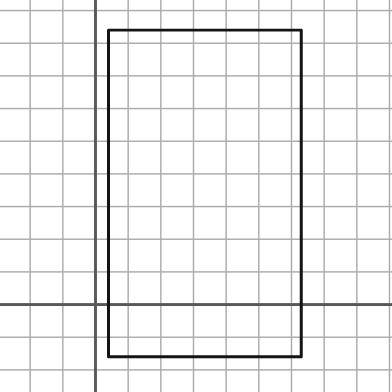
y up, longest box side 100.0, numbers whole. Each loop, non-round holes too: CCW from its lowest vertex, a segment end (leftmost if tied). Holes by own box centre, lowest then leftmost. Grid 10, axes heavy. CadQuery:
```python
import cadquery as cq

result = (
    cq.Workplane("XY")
    .moveTo(4.0, -16.0)
    .lineTo(63.0, -16.0)
    .lineTo(63.0, 84.0)
    .lineTo(4.0, 84.0)
    .close()
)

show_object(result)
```